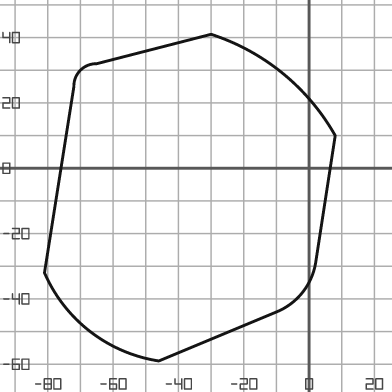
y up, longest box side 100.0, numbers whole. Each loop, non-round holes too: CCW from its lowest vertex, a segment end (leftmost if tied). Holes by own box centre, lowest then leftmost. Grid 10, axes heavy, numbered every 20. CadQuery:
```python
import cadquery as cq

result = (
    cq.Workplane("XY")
    .moveTo(-46.0, -59.0)
    .lineTo(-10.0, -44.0)
    .threePointArc((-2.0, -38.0), (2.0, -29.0))
    .lineTo(8.0, 10.0)
    .threePointArc((-8.0, 29.0), (-30.0, 41.0))
    .lineTo(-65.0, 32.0)
    .threePointArc((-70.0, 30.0), (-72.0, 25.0))
    .lineTo(-81.0, -32.0)
    .threePointArc((-67.0, -50.0), (-46.0, -59.0))
    .close()
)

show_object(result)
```